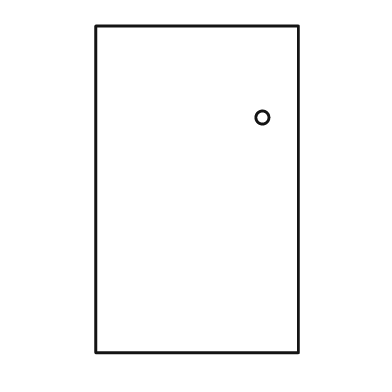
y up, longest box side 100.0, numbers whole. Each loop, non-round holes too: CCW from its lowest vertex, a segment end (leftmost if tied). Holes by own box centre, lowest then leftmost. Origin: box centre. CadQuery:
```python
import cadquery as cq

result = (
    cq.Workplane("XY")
    .moveTo(-31.0, -50.0)
    .lineTo(31.0, -50.0)
    .lineTo(31.0, 50.0)
    .lineTo(-31.0, 50.0)
    .close()
    .moveTo(20.0, 22.0)
    .circle(2.0)
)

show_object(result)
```